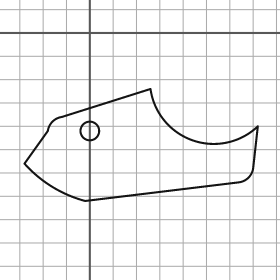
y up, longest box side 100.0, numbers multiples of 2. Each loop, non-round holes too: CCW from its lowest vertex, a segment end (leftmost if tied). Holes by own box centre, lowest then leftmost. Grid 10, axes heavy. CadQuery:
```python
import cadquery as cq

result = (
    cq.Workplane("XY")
    .moveTo(-2.0, -72.0)
    .lineTo(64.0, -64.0)
    .threePointArc((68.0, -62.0), (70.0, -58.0))
    .lineTo(72.0, -40.0)
    .threePointArc((44.0, -46.0), (26.0, -24.0))
    .lineTo(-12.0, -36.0)
    .threePointArc((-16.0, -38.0), (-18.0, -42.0))
    .lineTo(-28.0, -56.0)
    .threePointArc((-16.0, -66.0), (-2.0, -72.0))
    .close()
    .moveTo(0.0, -42.0)
    .circle(4.0)
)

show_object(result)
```